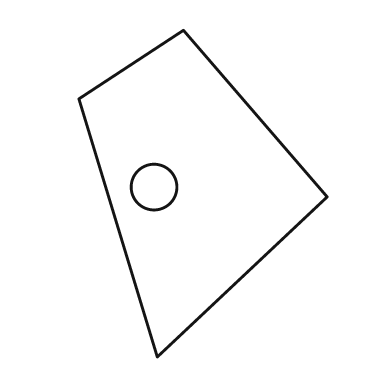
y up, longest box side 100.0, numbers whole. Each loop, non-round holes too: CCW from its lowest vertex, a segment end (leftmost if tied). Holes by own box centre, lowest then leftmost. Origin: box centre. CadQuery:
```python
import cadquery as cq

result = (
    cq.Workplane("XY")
    .moveTo(-14.0, -50.0)
    .lineTo(38.0, -1.0)
    .lineTo(-6.0, 50.0)
    .lineTo(-38.0, 29.0)
    .close()
    .moveTo(-15.0, 2.0)
    .circle(7.0)
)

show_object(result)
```